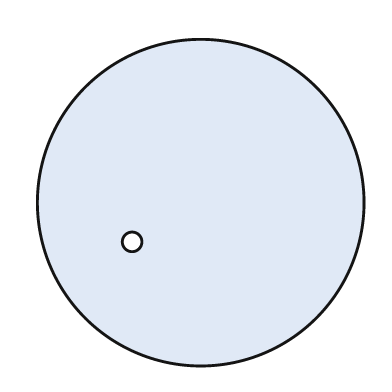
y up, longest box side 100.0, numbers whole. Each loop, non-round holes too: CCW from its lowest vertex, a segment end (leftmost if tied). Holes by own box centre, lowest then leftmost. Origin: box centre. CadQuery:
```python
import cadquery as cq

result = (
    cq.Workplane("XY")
    .moveTo(0.0, 0.0)
    .circle(50.0)
    .moveTo(-21.0, -12.0)
    .circle(3.0)
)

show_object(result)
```